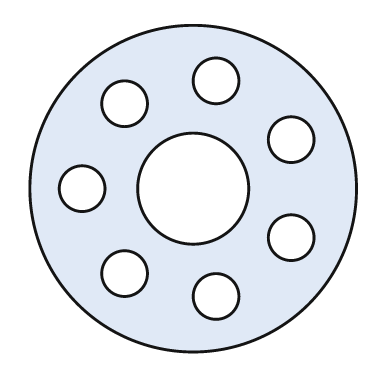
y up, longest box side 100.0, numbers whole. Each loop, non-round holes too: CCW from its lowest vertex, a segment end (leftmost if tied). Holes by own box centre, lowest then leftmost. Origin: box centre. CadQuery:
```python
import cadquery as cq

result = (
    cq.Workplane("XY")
    .moveTo(0.0, 0.0)
    .circle(50.0)
    .moveTo(7.0, -33.0)
    .circle(7.0)
    .moveTo(-21.0, -26.0)
    .circle(7.0)
    .moveTo(30.0, -15.0)
    .circle(7.0)
    .moveTo(-34.0, 0.0)
    .circle(7.0)
    .moveTo(0.0, 0.0)
    .circle(17.0)
    .moveTo(30.0, 15.0)
    .circle(7.0)
    .moveTo(-21.0, 26.0)
    .circle(7.0)
    .moveTo(7.0, 33.0)
    .circle(7.0)
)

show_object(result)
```